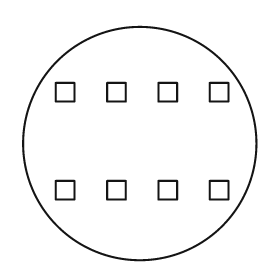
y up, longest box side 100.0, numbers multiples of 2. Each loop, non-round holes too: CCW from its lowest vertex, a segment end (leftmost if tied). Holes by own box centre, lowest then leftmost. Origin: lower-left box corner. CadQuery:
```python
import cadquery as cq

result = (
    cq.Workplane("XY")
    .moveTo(50.0, 50.0)
    .circle(50.0)
    .moveTo(14.0, 26.0)
    .lineTo(22.0, 26.0)
    .lineTo(22.0, 34.0)
    .lineTo(14.0, 34.0)
    .close()
    .moveTo(36.0, 26.0)
    .lineTo(44.0, 26.0)
    .lineTo(44.0, 34.0)
    .lineTo(36.0, 34.0)
    .close()
    .moveTo(58.0, 26.0)
    .lineTo(66.0, 26.0)
    .lineTo(66.0, 34.0)
    .lineTo(58.0, 34.0)
    .close()
    .moveTo(80.0, 26.0)
    .lineTo(88.0, 26.0)
    .lineTo(88.0, 34.0)
    .lineTo(80.0, 34.0)
    .close()
    .moveTo(14.0, 68.0)
    .lineTo(22.0, 68.0)
    .lineTo(22.0, 76.0)
    .lineTo(14.0, 76.0)
    .close()
    .moveTo(36.0, 68.0)
    .lineTo(44.0, 68.0)
    .lineTo(44.0, 76.0)
    .lineTo(36.0, 76.0)
    .close()
    .moveTo(58.0, 68.0)
    .lineTo(66.0, 68.0)
    .lineTo(66.0, 76.0)
    .lineTo(58.0, 76.0)
    .close()
    .moveTo(80.0, 68.0)
    .lineTo(88.0, 68.0)
    .lineTo(88.0, 76.0)
    .lineTo(80.0, 76.0)
    .close()
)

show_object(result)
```